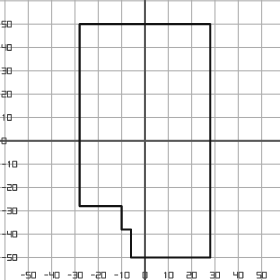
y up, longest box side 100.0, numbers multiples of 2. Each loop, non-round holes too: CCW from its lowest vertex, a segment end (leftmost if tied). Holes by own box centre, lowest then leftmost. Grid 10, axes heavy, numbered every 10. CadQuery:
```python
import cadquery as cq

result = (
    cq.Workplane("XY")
    .moveTo(-6.0, -50.0)
    .lineTo(28.0, -50.0)
    .lineTo(28.0, 50.0)
    .lineTo(-28.0, 50.0)
    .lineTo(-28.0, -28.0)
    .lineTo(-10.0, -28.0)
    .lineTo(-10.0, -38.0)
    .lineTo(-6.0, -38.0)
    .close()
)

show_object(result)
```